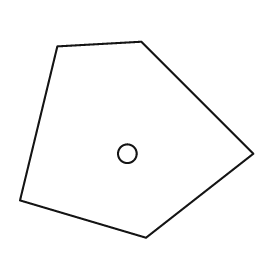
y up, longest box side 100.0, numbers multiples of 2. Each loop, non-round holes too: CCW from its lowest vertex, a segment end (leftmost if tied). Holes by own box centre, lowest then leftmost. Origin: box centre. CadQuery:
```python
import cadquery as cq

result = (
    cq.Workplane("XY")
    .moveTo(4.0, -42.0)
    .lineTo(50.0, -6.0)
    .lineTo(2.0, 42.0)
    .lineTo(-34.0, 40.0)
    .lineTo(-50.0, -26.0)
    .close()
    .moveTo(-4.0, -6.0)
    .circle(4.0)
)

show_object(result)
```